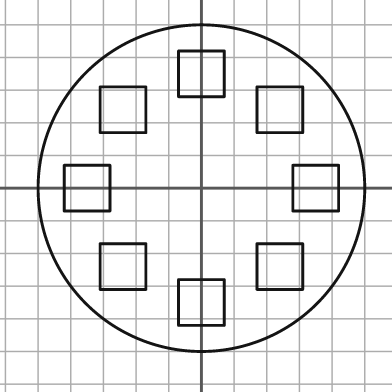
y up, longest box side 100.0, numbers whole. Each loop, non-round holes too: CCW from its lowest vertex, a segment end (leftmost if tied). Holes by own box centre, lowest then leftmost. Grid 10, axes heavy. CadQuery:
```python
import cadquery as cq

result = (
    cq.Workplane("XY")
    .moveTo(0.0, 0.0)
    .circle(50.0)
    .moveTo(-7.0, -42.0)
    .lineTo(7.0, -42.0)
    .lineTo(7.0, -28.0)
    .lineTo(-7.0, -28.0)
    .close()
    .moveTo(-31.0, -31.0)
    .lineTo(-17.0, -31.0)
    .lineTo(-17.0, -17.0)
    .lineTo(-31.0, -17.0)
    .close()
    .moveTo(17.0, -31.0)
    .lineTo(31.0, -31.0)
    .lineTo(31.0, -17.0)
    .lineTo(17.0, -17.0)
    .close()
    .moveTo(-42.0, -7.0)
    .lineTo(-28.0, -7.0)
    .lineTo(-28.0, 7.0)
    .lineTo(-42.0, 7.0)
    .close()
    .moveTo(28.0, -7.0)
    .lineTo(42.0, -7.0)
    .lineTo(42.0, 7.0)
    .lineTo(28.0, 7.0)
    .close()
    .moveTo(-31.0, 17.0)
    .lineTo(-17.0, 17.0)
    .lineTo(-17.0, 31.0)
    .lineTo(-31.0, 31.0)
    .close()
    .moveTo(17.0, 17.0)
    .lineTo(31.0, 17.0)
    .lineTo(31.0, 31.0)
    .lineTo(17.0, 31.0)
    .close()
    .moveTo(-7.0, 28.0)
    .lineTo(7.0, 28.0)
    .lineTo(7.0, 42.0)
    .lineTo(-7.0, 42.0)
    .close()
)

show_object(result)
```